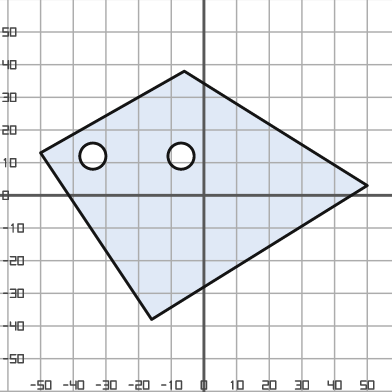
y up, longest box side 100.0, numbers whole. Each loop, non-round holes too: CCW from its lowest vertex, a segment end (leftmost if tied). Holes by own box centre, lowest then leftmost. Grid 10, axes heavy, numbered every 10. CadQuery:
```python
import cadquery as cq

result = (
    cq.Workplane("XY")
    .moveTo(-16.0, -38.0)
    .lineTo(50.0, 3.0)
    .lineTo(-6.0, 38.0)
    .lineTo(-50.0, 13.0)
    .close()
    .moveTo(-34.0, 12.0)
    .circle(4.0)
    .moveTo(-7.0, 12.0)
    .circle(4.0)
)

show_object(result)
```